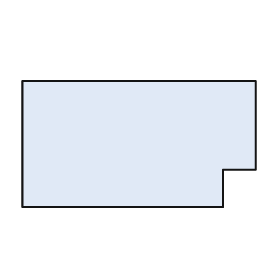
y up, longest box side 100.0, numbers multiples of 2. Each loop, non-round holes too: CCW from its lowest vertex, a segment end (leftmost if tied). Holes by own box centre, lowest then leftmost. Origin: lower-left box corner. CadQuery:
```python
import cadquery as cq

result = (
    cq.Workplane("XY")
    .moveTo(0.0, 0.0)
    .lineTo(86.0, 0.0)
    .lineTo(86.0, 16.0)
    .lineTo(100.0, 16.0)
    .lineTo(100.0, 54.0)
    .lineTo(0.0, 54.0)
    .close()
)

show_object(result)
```